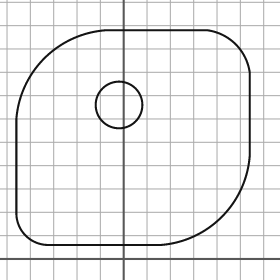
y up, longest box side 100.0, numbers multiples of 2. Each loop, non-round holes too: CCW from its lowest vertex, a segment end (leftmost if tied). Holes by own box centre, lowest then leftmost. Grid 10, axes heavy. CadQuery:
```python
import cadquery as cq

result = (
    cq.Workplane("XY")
    .moveTo(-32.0, 6.0)
    .lineTo(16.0, 6.0)
    .threePointArc((42.0, 18.0), (54.0, 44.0))
    .lineTo(54.0, 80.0)
    .threePointArc((48.0, 92.0), (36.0, 98.0))
    .lineTo(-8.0, 98.0)
    .threePointArc((-34.0, 86.0), (-46.0, 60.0))
    .lineTo(-46.0, 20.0)
    .threePointArc((-42.0, 10.0), (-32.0, 6.0))
    .close()
    .moveTo(-2.0, 66.0)
    .circle(10.0)
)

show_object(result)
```